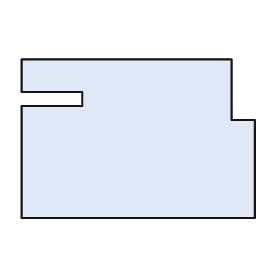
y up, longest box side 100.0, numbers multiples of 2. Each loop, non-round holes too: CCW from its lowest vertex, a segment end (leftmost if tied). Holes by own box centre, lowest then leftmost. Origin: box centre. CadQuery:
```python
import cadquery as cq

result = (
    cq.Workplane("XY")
    .moveTo(-50.0, -34.0)
    .lineTo(50.0, -34.0)
    .lineTo(50.0, 8.0)
    .lineTo(40.0, 8.0)
    .lineTo(40.0, 34.0)
    .lineTo(-50.0, 34.0)
    .lineTo(-50.0, 20.0)
    .lineTo(-24.0, 20.0)
    .lineTo(-24.0, 14.0)
    .lineTo(-50.0, 14.0)
    .close()
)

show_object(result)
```